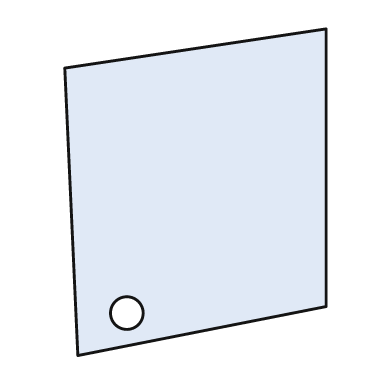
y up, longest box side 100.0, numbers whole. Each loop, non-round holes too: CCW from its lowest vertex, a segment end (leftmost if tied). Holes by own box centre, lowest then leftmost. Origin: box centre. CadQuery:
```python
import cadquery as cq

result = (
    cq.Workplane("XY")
    .moveTo(-36.0, -50.0)
    .lineTo(40.0, -35.0)
    .lineTo(40.0, 50.0)
    .lineTo(-40.0, 38.0)
    .close()
    .moveTo(-21.0, -37.0)
    .circle(5.0)
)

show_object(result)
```